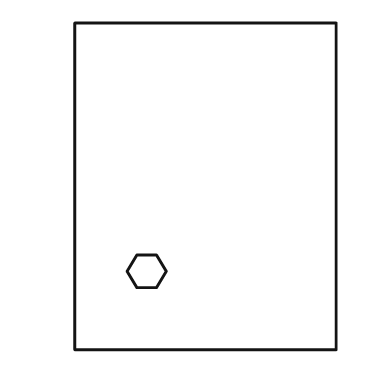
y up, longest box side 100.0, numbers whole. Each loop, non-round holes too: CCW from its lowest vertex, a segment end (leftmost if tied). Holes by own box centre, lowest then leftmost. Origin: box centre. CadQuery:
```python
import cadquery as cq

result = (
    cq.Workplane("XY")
    .moveTo(-40.0, -50.0)
    .lineTo(40.0, -50.0)
    .lineTo(40.0, 50.0)
    .lineTo(-40.0, 50.0)
    .close()
    .moveTo(-21.0, -31.0)
    .lineTo(-15.0, -31.0)
    .lineTo(-12.0, -26.0)
    .lineTo(-15.0, -21.0)
    .lineTo(-21.0, -21.0)
    .lineTo(-24.0, -26.0)
    .close()
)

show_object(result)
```